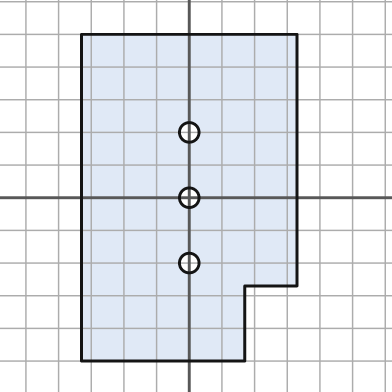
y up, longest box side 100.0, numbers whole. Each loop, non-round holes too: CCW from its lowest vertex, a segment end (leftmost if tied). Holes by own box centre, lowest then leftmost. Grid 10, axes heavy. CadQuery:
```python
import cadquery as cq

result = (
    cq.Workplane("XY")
    .moveTo(-33.0, -50.0)
    .lineTo(17.0, -50.0)
    .lineTo(17.0, -27.0)
    .lineTo(33.0, -27.0)
    .lineTo(33.0, 50.0)
    .lineTo(-33.0, 50.0)
    .close()
    .moveTo(0.0, -20.0)
    .circle(3.0)
    .moveTo(0.0, 0.0)
    .circle(3.0)
    .moveTo(0.0, 20.0)
    .circle(3.0)
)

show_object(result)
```